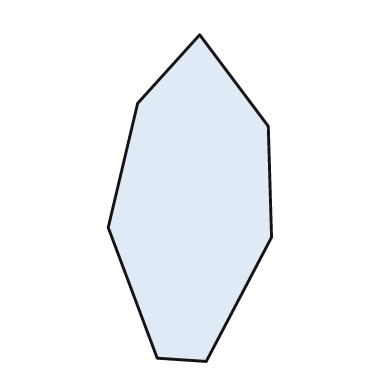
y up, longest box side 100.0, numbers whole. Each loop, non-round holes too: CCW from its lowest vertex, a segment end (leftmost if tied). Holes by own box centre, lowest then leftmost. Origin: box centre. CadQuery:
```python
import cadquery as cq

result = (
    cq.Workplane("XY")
    .moveTo(5.0, -50.0)
    .lineTo(25.0, -12.0)
    .lineTo(24.0, 22.0)
    .lineTo(3.0, 50.0)
    .lineTo(-16.0, 29.0)
    .lineTo(-25.0, -9.0)
    .lineTo(-10.0, -49.0)
    .close()
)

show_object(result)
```